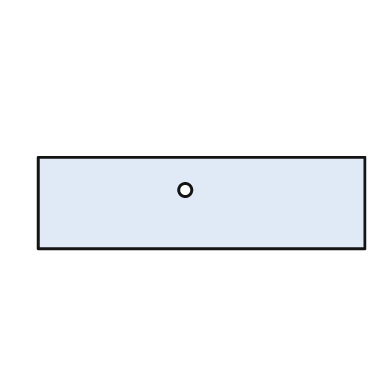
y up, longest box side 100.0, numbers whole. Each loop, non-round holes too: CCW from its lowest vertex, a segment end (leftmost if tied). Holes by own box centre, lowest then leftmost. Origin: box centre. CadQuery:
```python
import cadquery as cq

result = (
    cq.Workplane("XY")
    .moveTo(-50.0, -14.0)
    .lineTo(50.0, -14.0)
    .lineTo(50.0, 14.0)
    .lineTo(-50.0, 14.0)
    .close()
    .moveTo(-5.0, 4.0)
    .circle(2.0)
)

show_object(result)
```